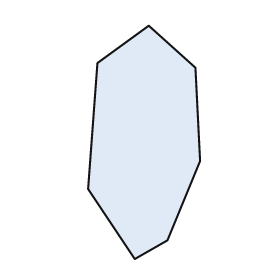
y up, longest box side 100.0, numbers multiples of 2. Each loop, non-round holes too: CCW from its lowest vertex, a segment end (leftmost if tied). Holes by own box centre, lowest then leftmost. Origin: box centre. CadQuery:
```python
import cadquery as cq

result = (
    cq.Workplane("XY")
    .moveTo(-4.0, -50.0)
    .lineTo(10.0, -42.0)
    .lineTo(24.0, -8.0)
    .lineTo(22.0, 32.0)
    .lineTo(2.0, 50.0)
    .lineTo(-20.0, 34.0)
    .lineTo(-24.0, -20.0)
    .close()
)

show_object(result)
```